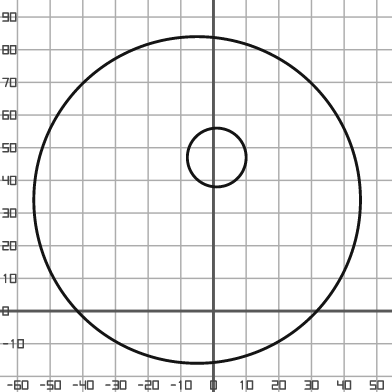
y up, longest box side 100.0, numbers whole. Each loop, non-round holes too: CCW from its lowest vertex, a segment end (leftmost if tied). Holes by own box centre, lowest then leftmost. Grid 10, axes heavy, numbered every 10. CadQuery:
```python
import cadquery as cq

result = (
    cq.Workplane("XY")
    .moveTo(-5.0, 34.0)
    .circle(50.0)
    .moveTo(1.0, 47.0)
    .circle(9.0)
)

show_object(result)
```